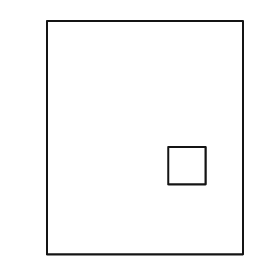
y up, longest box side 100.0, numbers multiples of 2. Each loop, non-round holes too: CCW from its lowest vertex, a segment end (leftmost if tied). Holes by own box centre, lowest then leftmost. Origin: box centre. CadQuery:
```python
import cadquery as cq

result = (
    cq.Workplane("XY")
    .moveTo(-42.0, -50.0)
    .lineTo(42.0, -50.0)
    .lineTo(42.0, 50.0)
    .lineTo(-42.0, 50.0)
    .close()
    .moveTo(10.0, -20.0)
    .lineTo(26.0, -20.0)
    .lineTo(26.0, -4.0)
    .lineTo(10.0, -4.0)
    .close()
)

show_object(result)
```